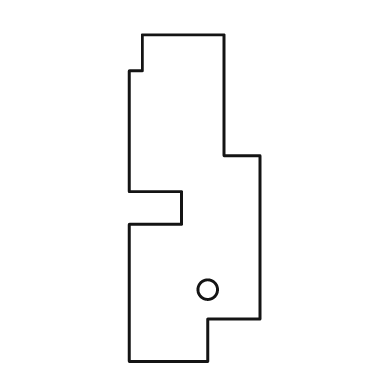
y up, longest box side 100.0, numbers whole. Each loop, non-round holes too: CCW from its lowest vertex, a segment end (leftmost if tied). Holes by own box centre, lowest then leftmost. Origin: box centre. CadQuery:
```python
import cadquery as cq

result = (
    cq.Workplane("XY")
    .moveTo(-20.0, -50.0)
    .lineTo(4.0, -50.0)
    .lineTo(4.0, -37.0)
    .lineTo(20.0, -37.0)
    .lineTo(20.0, 13.0)
    .lineTo(9.0, 13.0)
    .lineTo(9.0, 50.0)
    .lineTo(-16.0, 50.0)
    .lineTo(-16.0, 39.0)
    .lineTo(-20.0, 39.0)
    .lineTo(-20.0, 2.0)
    .lineTo(-4.0, 2.0)
    .lineTo(-4.0, -8.0)
    .lineTo(-20.0, -8.0)
    .close()
    .moveTo(4.0, -28.0)
    .circle(3.0)
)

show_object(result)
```